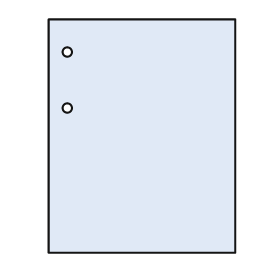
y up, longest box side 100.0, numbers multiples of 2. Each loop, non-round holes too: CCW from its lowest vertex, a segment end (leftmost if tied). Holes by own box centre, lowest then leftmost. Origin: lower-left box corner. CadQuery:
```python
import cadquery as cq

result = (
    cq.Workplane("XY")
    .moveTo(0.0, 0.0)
    .lineTo(80.0, 0.0)
    .lineTo(80.0, 100.0)
    .lineTo(0.0, 100.0)
    .close()
    .moveTo(8.0, 62.0)
    .circle(2.0)
    .moveTo(8.0, 86.0)
    .circle(2.0)
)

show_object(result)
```